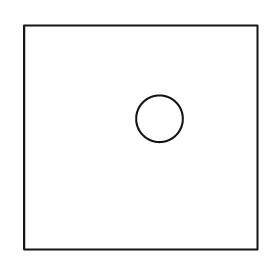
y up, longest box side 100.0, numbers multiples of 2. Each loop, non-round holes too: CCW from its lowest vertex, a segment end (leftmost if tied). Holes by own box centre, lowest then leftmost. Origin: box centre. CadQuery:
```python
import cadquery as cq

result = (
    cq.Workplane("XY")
    .moveTo(-50.0, -48.0)
    .lineTo(50.0, -48.0)
    .lineTo(50.0, 48.0)
    .lineTo(-50.0, 48.0)
    .close()
    .moveTo(8.0, 8.0)
    .circle(10.0)
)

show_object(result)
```